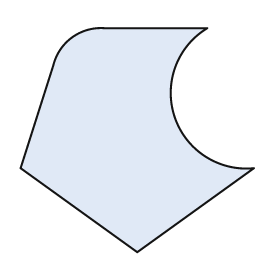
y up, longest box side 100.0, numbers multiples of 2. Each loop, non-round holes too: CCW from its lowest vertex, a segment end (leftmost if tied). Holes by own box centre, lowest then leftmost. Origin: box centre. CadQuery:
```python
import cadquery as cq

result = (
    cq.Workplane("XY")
    .moveTo(0.0, -48.0)
    .lineTo(50.0, -12.0)
    .threePointArc((16.0, 10.0), (30.0, 48.0))
    .lineTo(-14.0, 48.0)
    .threePointArc((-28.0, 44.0), (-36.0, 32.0))
    .lineTo(-50.0, -12.0)
    .close()
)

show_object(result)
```